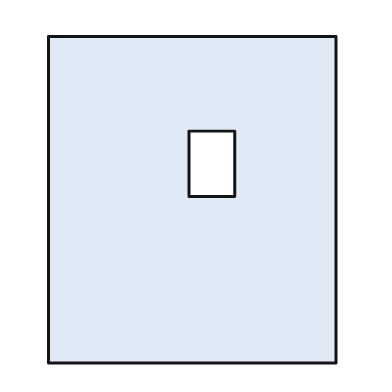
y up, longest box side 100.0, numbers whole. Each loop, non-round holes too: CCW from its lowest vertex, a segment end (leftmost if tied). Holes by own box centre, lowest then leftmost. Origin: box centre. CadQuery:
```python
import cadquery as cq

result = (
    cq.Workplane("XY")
    .moveTo(-44.0, -50.0)
    .lineTo(44.0, -50.0)
    .lineTo(44.0, 50.0)
    .lineTo(-44.0, 50.0)
    .close()
    .moveTo(-1.0, 1.0)
    .lineTo(13.0, 1.0)
    .lineTo(13.0, 21.0)
    .lineTo(-1.0, 21.0)
    .close()
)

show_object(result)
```